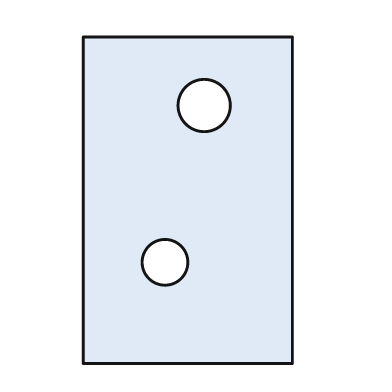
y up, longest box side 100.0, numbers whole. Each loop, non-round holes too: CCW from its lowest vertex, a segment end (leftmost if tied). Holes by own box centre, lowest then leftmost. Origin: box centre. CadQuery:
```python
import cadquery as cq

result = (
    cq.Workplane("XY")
    .moveTo(-32.0, -50.0)
    .lineTo(32.0, -50.0)
    .lineTo(32.0, 50.0)
    .lineTo(-32.0, 50.0)
    .close()
    .moveTo(-7.0, -19.0)
    .circle(7.0)
    .moveTo(5.0, 29.0)
    .circle(8.0)
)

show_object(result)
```